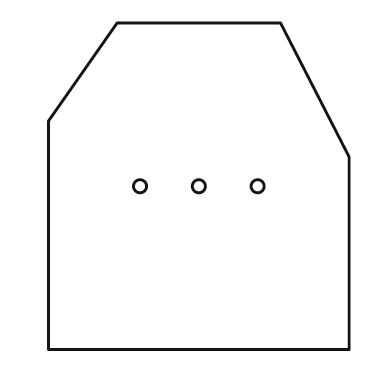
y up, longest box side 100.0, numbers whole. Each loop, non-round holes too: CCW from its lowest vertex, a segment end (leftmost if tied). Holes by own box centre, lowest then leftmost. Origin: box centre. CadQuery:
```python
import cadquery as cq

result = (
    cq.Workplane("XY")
    .moveTo(-46.0, -50.0)
    .lineTo(46.0, -50.0)
    .lineTo(46.0, 9.0)
    .lineTo(25.0, 50.0)
    .lineTo(-25.0, 50.0)
    .lineTo(-46.0, 20.0)
    .close()
    .moveTo(-18.0, 0.0)
    .circle(2.0)
    .moveTo(0.0, 0.0)
    .circle(2.0)
    .moveTo(18.0, 0.0)
    .circle(2.0)
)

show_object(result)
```